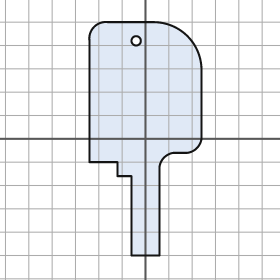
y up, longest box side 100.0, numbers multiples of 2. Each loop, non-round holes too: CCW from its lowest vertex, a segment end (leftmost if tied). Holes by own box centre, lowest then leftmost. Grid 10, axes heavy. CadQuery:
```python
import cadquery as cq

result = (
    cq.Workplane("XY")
    .moveTo(-6.0, -50.0)
    .lineTo(6.0, -50.0)
    .lineTo(6.0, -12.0)
    .threePointArc((8.0, -8.0), (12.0, -6.0))
    .lineTo(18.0, -6.0)
    .threePointArc((22.0, -4.0), (24.0, 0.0))
    .lineTo(24.0, 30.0)
    .threePointArc((18.0, 44.0), (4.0, 50.0))
    .lineTo(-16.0, 50.0)
    .threePointArc((-22.0, 48.0), (-24.0, 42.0))
    .lineTo(-24.0, -10.0)
    .lineTo(-12.0, -10.0)
    .lineTo(-12.0, -16.0)
    .lineTo(-6.0, -16.0)
    .close()
    .moveTo(-4.0, 42.0)
    .circle(2.0)
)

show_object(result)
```